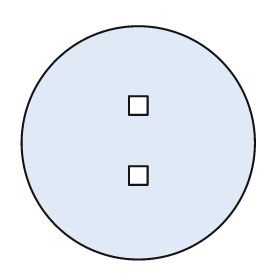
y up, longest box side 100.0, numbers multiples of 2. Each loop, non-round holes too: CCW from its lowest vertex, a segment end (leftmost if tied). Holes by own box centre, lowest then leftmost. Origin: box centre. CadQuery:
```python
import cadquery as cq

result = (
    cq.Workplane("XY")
    .moveTo(0.0, 0.0)
    .circle(50.0)
    .moveTo(-4.0, -18.0)
    .lineTo(4.0, -18.0)
    .lineTo(4.0, -10.0)
    .lineTo(-4.0, -10.0)
    .close()
    .moveTo(-4.0, 12.0)
    .lineTo(4.0, 12.0)
    .lineTo(4.0, 20.0)
    .lineTo(-4.0, 20.0)
    .close()
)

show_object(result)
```